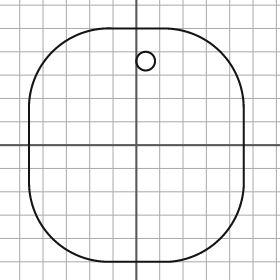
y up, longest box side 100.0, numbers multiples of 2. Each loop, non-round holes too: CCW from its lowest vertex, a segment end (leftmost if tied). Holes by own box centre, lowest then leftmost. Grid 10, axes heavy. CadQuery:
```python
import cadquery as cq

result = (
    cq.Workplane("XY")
    .moveTo(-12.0, -50.0)
    .lineTo(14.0, -50.0)
    .threePointArc((36.0, -40.0), (46.0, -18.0))
    .lineTo(46.0, 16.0)
    .threePointArc((36.0, 40.0), (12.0, 50.0))
    .lineTo(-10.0, 50.0)
    .threePointArc((-36.0, 40.0), (-46.0, 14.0))
    .lineTo(-46.0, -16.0)
    .threePointArc((-36.0, -40.0), (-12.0, -50.0))
    .close()
    .moveTo(4.0, 36.0)
    .circle(4.0)
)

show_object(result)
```